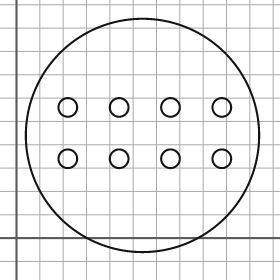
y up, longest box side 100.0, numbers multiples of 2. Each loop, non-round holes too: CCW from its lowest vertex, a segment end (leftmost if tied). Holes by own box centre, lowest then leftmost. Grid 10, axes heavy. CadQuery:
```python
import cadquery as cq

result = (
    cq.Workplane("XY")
    .moveTo(54.0, 44.0)
    .circle(50.0)
    .moveTo(22.0, 34.0)
    .circle(4.0)
    .moveTo(44.0, 34.0)
    .circle(4.0)
    .moveTo(66.0, 34.0)
    .circle(4.0)
    .moveTo(88.0, 34.0)
    .circle(4.0)
    .moveTo(22.0, 56.0)
    .circle(4.0)
    .moveTo(44.0, 56.0)
    .circle(4.0)
    .moveTo(66.0, 56.0)
    .circle(4.0)
    .moveTo(88.0, 56.0)
    .circle(4.0)
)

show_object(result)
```